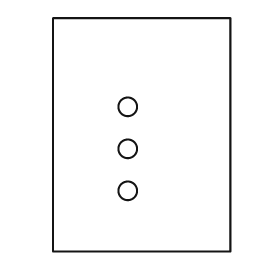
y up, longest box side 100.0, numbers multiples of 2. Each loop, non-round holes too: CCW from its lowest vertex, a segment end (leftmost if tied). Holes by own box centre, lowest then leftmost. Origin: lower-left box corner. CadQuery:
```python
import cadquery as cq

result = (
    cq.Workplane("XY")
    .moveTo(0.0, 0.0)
    .lineTo(76.0, 0.0)
    .lineTo(76.0, 100.0)
    .lineTo(0.0, 100.0)
    .close()
    .moveTo(32.0, 26.0)
    .circle(4.0)
    .moveTo(32.0, 44.0)
    .circle(4.0)
    .moveTo(32.0, 62.0)
    .circle(4.0)
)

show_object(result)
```